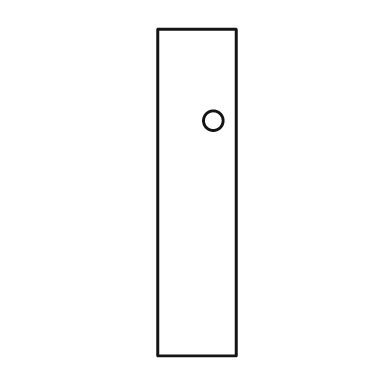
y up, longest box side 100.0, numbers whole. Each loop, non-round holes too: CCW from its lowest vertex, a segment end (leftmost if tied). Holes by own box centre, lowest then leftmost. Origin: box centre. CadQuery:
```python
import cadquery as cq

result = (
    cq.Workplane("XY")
    .moveTo(-12.0, -50.0)
    .lineTo(12.0, -50.0)
    .lineTo(12.0, 50.0)
    .lineTo(-12.0, 50.0)
    .close()
    .moveTo(5.0, 22.0)
    .circle(3.0)
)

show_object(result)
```